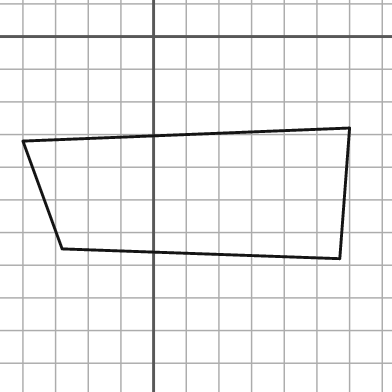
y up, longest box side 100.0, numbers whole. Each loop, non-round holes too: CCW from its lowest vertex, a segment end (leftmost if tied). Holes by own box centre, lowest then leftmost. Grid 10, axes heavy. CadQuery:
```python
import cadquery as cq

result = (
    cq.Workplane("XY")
    .moveTo(57.0, -68.0)
    .lineTo(60.0, -28.0)
    .lineTo(-40.0, -32.0)
    .lineTo(-28.0, -65.0)
    .close()
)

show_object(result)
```